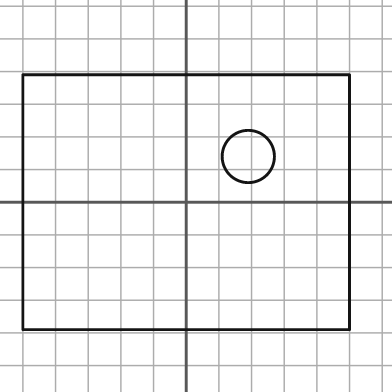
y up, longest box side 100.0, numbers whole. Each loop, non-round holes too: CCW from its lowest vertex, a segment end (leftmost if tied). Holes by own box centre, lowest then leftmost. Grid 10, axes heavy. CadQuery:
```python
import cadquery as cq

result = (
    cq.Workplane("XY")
    .moveTo(-50.0, -39.0)
    .lineTo(50.0, -39.0)
    .lineTo(50.0, 39.0)
    .lineTo(-50.0, 39.0)
    .close()
    .moveTo(19.0, 14.0)
    .circle(8.0)
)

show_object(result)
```